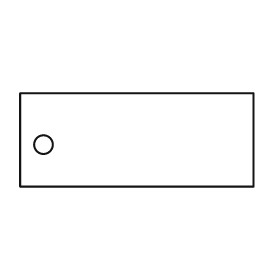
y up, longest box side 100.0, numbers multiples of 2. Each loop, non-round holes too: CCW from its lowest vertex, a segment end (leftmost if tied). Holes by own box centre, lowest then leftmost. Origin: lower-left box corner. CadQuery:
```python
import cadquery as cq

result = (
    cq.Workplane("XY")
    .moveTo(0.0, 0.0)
    .lineTo(100.0, 0.0)
    .lineTo(100.0, 40.0)
    .lineTo(0.0, 40.0)
    .close()
    .moveTo(10.0, 18.0)
    .circle(4.0)
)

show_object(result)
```